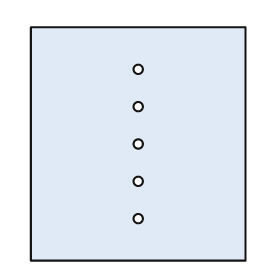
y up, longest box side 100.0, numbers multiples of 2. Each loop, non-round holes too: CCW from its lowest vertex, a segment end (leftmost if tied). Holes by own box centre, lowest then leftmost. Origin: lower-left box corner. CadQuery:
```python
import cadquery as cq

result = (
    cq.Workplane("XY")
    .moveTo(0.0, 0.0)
    .lineTo(92.0, 0.0)
    .lineTo(92.0, 100.0)
    .lineTo(0.0, 100.0)
    .close()
    .moveTo(46.0, 18.0)
    .circle(2.0)
    .moveTo(46.0, 34.0)
    .circle(2.0)
    .moveTo(46.0, 50.0)
    .circle(2.0)
    .moveTo(46.0, 66.0)
    .circle(2.0)
    .moveTo(46.0, 82.0)
    .circle(2.0)
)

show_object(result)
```